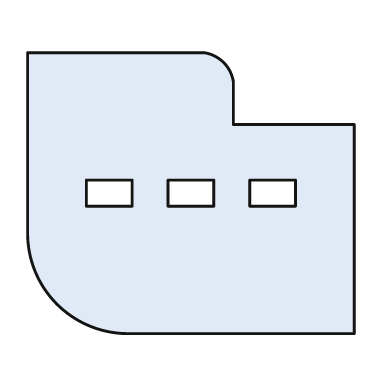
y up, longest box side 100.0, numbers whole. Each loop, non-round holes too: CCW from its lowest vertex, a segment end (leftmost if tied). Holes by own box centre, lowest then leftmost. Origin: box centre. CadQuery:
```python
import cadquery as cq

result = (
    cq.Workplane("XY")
    .moveTo(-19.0, -43.0)
    .lineTo(50.0, -43.0)
    .lineTo(50.0, 21.0)
    .lineTo(13.0, 21.0)
    .lineTo(13.0, 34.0)
    .threePointArc((10.0, 40.0), (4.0, 43.0))
    .lineTo(-50.0, 43.0)
    .lineTo(-50.0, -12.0)
    .threePointArc((-41.0, -34.0), (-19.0, -43.0))
    .close()
    .moveTo(-32.0, -4.0)
    .lineTo(-18.0, -4.0)
    .lineTo(-18.0, 4.0)
    .lineTo(-32.0, 4.0)
    .close()
    .moveTo(-7.0, -4.0)
    .lineTo(7.0, -4.0)
    .lineTo(7.0, 4.0)
    .lineTo(-7.0, 4.0)
    .close()
    .moveTo(18.0, -4.0)
    .lineTo(32.0, -4.0)
    .lineTo(32.0, 4.0)
    .lineTo(18.0, 4.0)
    .close()
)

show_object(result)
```